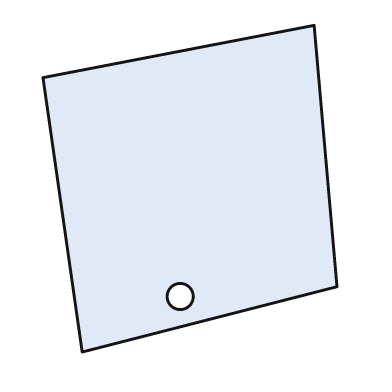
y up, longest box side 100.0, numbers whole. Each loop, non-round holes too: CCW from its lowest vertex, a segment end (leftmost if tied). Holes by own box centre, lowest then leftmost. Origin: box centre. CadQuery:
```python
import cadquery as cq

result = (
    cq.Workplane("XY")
    .moveTo(-33.0, -50.0)
    .lineTo(45.0, -30.0)
    .lineTo(38.0, 50.0)
    .lineTo(-45.0, 34.0)
    .close()
    .moveTo(-3.0, -33.0)
    .circle(4.0)
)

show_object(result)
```